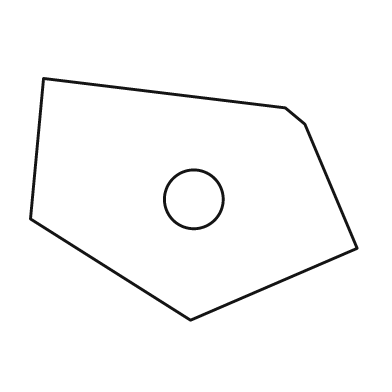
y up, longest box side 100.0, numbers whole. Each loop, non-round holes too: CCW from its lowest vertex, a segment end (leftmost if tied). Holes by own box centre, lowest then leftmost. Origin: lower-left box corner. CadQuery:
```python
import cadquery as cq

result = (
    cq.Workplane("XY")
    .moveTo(49.0, 0.0)
    .lineTo(100.0, 22.0)
    .lineTo(84.0, 60.0)
    .lineTo(78.0, 65.0)
    .lineTo(4.0, 74.0)
    .lineTo(0.0, 31.0)
    .close()
    .moveTo(50.0, 37.0)
    .circle(9.0)
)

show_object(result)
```